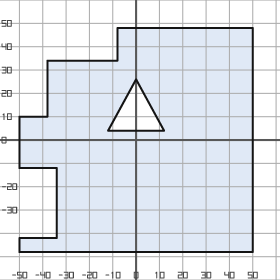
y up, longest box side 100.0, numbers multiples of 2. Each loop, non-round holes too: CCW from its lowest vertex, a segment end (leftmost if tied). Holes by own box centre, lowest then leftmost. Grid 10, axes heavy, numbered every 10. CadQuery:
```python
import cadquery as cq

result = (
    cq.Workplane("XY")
    .moveTo(-50.0, -48.0)
    .lineTo(50.0, -48.0)
    .lineTo(50.0, 48.0)
    .lineTo(-8.0, 48.0)
    .lineTo(-8.0, 34.0)
    .lineTo(-38.0, 34.0)
    .lineTo(-38.0, 10.0)
    .lineTo(-50.0, 10.0)
    .lineTo(-50.0, -12.0)
    .lineTo(-34.0, -12.0)
    .lineTo(-34.0, -42.0)
    .lineTo(-50.0, -42.0)
    .close()
    .moveTo(-12.0, 4.0)
    .lineTo(12.0, 4.0)
    .lineTo(0.0, 26.0)
    .close()
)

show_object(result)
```